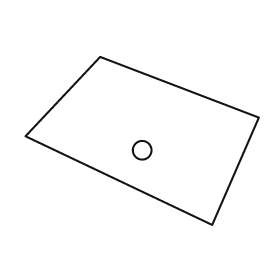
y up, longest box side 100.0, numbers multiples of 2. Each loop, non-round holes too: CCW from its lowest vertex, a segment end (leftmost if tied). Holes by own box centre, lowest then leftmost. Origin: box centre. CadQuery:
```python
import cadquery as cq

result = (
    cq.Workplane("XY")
    .moveTo(30.0, -36.0)
    .lineTo(50.0, 10.0)
    .lineTo(-18.0, 36.0)
    .lineTo(-50.0, 2.0)
    .close()
    .moveTo(0.0, -4.0)
    .circle(4.0)
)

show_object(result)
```